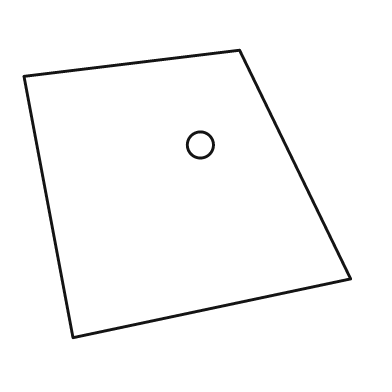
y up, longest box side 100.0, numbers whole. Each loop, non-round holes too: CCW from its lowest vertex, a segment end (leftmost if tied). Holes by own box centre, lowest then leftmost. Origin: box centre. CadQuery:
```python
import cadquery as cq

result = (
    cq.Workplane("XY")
    .moveTo(-35.0, -44.0)
    .lineTo(50.0, -26.0)
    .lineTo(16.0, 44.0)
    .lineTo(-50.0, 36.0)
    .close()
    .moveTo(4.0, 15.0)
    .circle(4.0)
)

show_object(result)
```